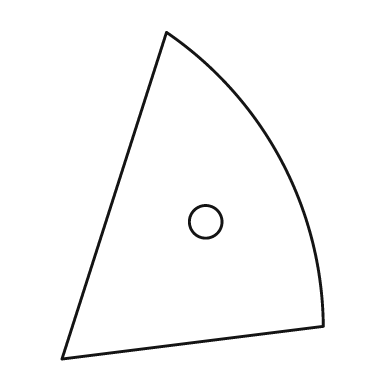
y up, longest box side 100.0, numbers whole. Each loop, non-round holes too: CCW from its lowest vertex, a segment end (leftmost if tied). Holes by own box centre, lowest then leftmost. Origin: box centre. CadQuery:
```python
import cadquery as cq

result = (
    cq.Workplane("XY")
    .moveTo(-40.0, -50.0)
    .lineTo(40.0, -40.0)
    .threePointArc((27.0, 11.0), (-8.0, 50.0))
    .close()
    .moveTo(4.0, -8.0)
    .circle(5.0)
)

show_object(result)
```